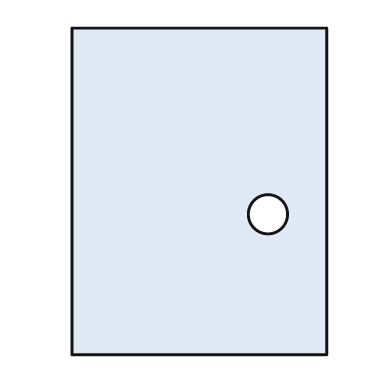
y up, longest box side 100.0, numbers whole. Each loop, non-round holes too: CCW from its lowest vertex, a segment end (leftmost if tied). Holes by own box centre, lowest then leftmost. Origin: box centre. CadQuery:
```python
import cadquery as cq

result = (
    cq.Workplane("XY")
    .moveTo(-39.0, -50.0)
    .lineTo(39.0, -50.0)
    .lineTo(39.0, 50.0)
    .lineTo(-39.0, 50.0)
    .close()
    .moveTo(21.0, -7.0)
    .circle(6.0)
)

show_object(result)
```